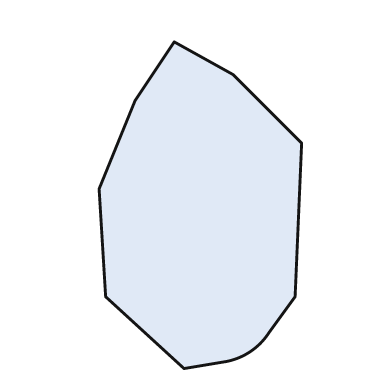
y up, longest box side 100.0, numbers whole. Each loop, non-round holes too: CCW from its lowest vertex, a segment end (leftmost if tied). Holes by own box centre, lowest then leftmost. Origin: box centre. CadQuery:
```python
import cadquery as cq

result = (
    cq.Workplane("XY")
    .moveTo(-5.0, -50.0)
    .lineTo(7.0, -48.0)
    .threePointArc((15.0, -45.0), (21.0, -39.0))
    .lineTo(29.0, -28.0)
    .lineTo(31.0, 19.0)
    .lineTo(10.0, 40.0)
    .lineTo(-8.0, 50.0)
    .lineTo(-20.0, 32.0)
    .lineTo(-31.0, 5.0)
    .lineTo(-29.0, -28.0)
    .close()
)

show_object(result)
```